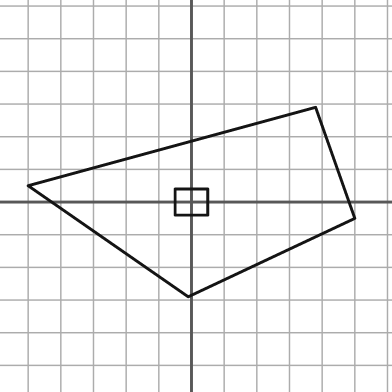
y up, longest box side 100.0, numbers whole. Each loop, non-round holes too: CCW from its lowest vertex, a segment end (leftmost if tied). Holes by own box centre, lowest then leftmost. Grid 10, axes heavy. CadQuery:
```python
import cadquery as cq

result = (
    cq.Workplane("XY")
    .moveTo(-1.0, -29.0)
    .lineTo(50.0, -5.0)
    .lineTo(38.0, 29.0)
    .lineTo(-50.0, 5.0)
    .close()
    .moveTo(-5.0, -4.0)
    .lineTo(5.0, -4.0)
    .lineTo(5.0, 4.0)
    .lineTo(-5.0, 4.0)
    .close()
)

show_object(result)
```